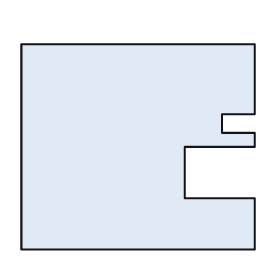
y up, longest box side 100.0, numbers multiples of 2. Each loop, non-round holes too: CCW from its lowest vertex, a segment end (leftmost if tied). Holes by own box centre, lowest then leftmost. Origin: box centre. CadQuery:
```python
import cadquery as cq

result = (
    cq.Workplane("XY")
    .moveTo(-50.0, -44.0)
    .lineTo(50.0, -44.0)
    .lineTo(50.0, -22.0)
    .lineTo(20.0, -22.0)
    .lineTo(20.0, 0.0)
    .lineTo(50.0, 0.0)
    .lineTo(50.0, 6.0)
    .lineTo(36.0, 6.0)
    .lineTo(36.0, 14.0)
    .lineTo(50.0, 14.0)
    .lineTo(50.0, 44.0)
    .lineTo(-50.0, 44.0)
    .close()
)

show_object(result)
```